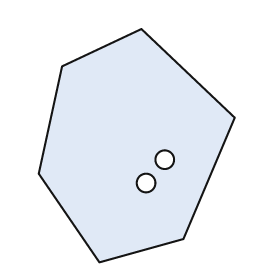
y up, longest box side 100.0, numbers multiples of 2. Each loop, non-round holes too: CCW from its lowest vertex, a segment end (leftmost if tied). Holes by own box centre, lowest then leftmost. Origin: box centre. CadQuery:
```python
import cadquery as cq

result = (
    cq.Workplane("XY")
    .moveTo(-16.0, -50.0)
    .lineTo(20.0, -40.0)
    .lineTo(42.0, 12.0)
    .lineTo(2.0, 50.0)
    .lineTo(-32.0, 34.0)
    .lineTo(-42.0, -12.0)
    .close()
    .moveTo(4.0, -16.0)
    .circle(4.0)
    .moveTo(12.0, -6.0)
    .circle(4.0)
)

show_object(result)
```